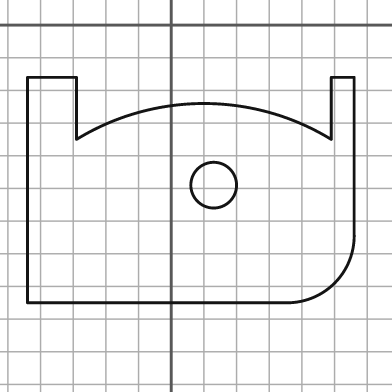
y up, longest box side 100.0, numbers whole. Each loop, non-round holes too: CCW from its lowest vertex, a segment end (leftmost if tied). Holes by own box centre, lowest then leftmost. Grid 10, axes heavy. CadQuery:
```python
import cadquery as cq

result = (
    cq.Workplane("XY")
    .moveTo(-44.0, -85.0)
    .lineTo(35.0, -85.0)
    .threePointArc((50.0, -79.0), (56.0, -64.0))
    .lineTo(56.0, -16.0)
    .lineTo(49.0, -16.0)
    .lineTo(49.0, -35.0)
    .threePointArc((10.0, -24.0), (-29.0, -35.0))
    .lineTo(-29.0, -16.0)
    .lineTo(-44.0, -16.0)
    .close()
    .moveTo(13.0, -49.0)
    .circle(7.0)
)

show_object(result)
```